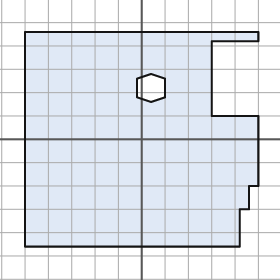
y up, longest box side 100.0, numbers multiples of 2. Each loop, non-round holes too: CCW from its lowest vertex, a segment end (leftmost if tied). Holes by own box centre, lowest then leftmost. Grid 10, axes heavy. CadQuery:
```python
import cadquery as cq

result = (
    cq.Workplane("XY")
    .moveTo(-50.0, -46.0)
    .lineTo(42.0, -46.0)
    .lineTo(42.0, -30.0)
    .lineTo(46.0, -30.0)
    .lineTo(46.0, -20.0)
    .lineTo(50.0, -20.0)
    .lineTo(50.0, 10.0)
    .lineTo(30.0, 10.0)
    .lineTo(30.0, 42.0)
    .lineTo(50.0, 42.0)
    .lineTo(50.0, 46.0)
    .lineTo(-50.0, 46.0)
    .close()
    .moveTo(4.0, 16.0)
    .lineTo(10.0, 18.0)
    .lineTo(10.0, 26.0)
    .lineTo(4.0, 28.0)
    .lineTo(-2.0, 26.0)
    .lineTo(-2.0, 18.0)
    .close()
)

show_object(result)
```